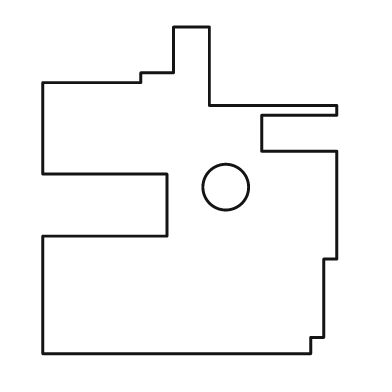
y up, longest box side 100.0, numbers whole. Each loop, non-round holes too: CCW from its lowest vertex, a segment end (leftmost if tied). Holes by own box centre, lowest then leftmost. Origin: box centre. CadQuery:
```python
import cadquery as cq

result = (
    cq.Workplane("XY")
    .moveTo(-45.0, -50.0)
    .lineTo(37.0, -50.0)
    .lineTo(37.0, -45.0)
    .lineTo(41.0, -45.0)
    .lineTo(41.0, -21.0)
    .lineTo(45.0, -21.0)
    .lineTo(45.0, 12.0)
    .lineTo(22.0, 12.0)
    .lineTo(22.0, 23.0)
    .lineTo(45.0, 23.0)
    .lineTo(45.0, 26.0)
    .lineTo(6.0, 26.0)
    .lineTo(6.0, 50.0)
    .lineTo(-5.0, 50.0)
    .lineTo(-5.0, 36.0)
    .lineTo(-15.0, 36.0)
    .lineTo(-15.0, 33.0)
    .lineTo(-45.0, 33.0)
    .lineTo(-45.0, 5.0)
    .lineTo(-7.0, 5.0)
    .lineTo(-7.0, -14.0)
    .lineTo(-45.0, -14.0)
    .close()
    .moveTo(11.0, 1.0)
    .circle(7.0)
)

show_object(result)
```